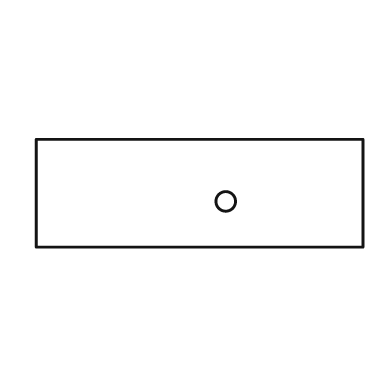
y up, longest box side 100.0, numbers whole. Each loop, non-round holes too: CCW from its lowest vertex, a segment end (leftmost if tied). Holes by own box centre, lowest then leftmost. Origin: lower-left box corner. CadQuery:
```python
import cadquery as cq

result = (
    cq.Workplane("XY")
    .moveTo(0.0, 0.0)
    .lineTo(100.0, 0.0)
    .lineTo(100.0, 33.0)
    .lineTo(0.0, 33.0)
    .close()
    .moveTo(58.0, 14.0)
    .circle(3.0)
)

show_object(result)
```